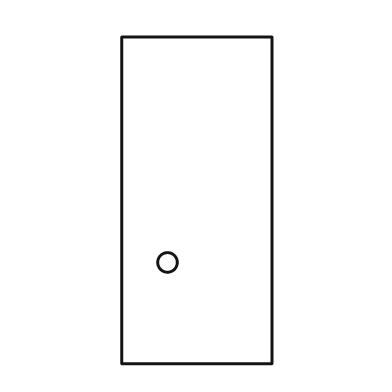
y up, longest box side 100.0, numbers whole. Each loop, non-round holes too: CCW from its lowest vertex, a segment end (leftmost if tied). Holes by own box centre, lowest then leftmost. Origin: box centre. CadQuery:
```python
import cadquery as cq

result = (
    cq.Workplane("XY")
    .moveTo(-23.0, -50.0)
    .lineTo(23.0, -50.0)
    .lineTo(23.0, 50.0)
    .lineTo(-23.0, 50.0)
    .close()
    .moveTo(-9.0, -19.0)
    .circle(3.0)
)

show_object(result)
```